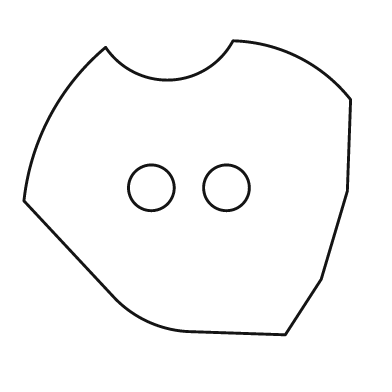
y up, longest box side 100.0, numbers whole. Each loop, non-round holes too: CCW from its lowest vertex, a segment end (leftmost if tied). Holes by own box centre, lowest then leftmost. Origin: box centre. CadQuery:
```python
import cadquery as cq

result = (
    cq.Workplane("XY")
    .moveTo(30.0, -45.0)
    .lineTo(41.0, -28.0)
    .lineTo(49.0, -1.0)
    .lineTo(50.0, 27.0)
    .threePointArc((34.0, 40.0), (14.0, 45.0))
    .threePointArc((-5.0, 33.0), (-25.0, 43.0))
    .threePointArc((-42.0, 22.0), (-50.0, -4.0))
    .lineTo(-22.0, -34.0)
    .threePointArc((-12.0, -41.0), (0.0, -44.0))
    .close()
    .moveTo(-11.0, 0.0)
    .circle(7.0)
    .moveTo(12.0, 0.0)
    .circle(7.0)
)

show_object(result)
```